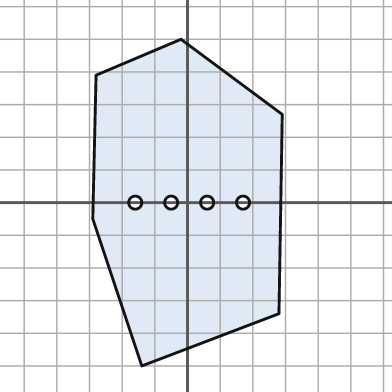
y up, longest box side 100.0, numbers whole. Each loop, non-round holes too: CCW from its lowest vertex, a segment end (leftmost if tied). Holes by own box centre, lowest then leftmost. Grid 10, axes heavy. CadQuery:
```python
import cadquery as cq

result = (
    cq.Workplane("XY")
    .moveTo(-14.0, -50.0)
    .lineTo(28.0, -34.0)
    .lineTo(29.0, 27.0)
    .lineTo(-2.0, 50.0)
    .lineTo(-28.0, 39.0)
    .lineTo(-29.0, -5.0)
    .close()
    .moveTo(-16.0, 0.0)
    .circle(2.0)
    .moveTo(-5.0, 0.0)
    .circle(2.0)
    .moveTo(6.0, 0.0)
    .circle(2.0)
    .moveTo(17.0, 0.0)
    .circle(2.0)
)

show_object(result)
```